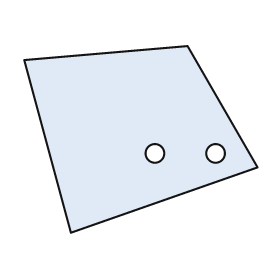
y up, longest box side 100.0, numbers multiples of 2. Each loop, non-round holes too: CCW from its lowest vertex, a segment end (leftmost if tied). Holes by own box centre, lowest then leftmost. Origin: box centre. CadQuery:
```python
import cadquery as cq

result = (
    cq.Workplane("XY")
    .moveTo(-30.0, -40.0)
    .lineTo(50.0, -12.0)
    .lineTo(20.0, 40.0)
    .lineTo(-50.0, 34.0)
    .close()
    .moveTo(6.0, -6.0)
    .circle(4.0)
    .moveTo(32.0, -6.0)
    .circle(4.0)
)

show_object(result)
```